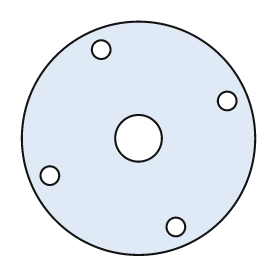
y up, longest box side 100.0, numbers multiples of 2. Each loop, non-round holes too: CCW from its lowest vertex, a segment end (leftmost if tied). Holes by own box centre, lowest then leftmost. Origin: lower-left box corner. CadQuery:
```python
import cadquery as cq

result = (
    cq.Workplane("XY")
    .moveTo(50.0, 50.0)
    .circle(50.0)
    .moveTo(66.0, 12.0)
    .circle(4.0)
    .moveTo(12.0, 34.0)
    .circle(4.0)
    .moveTo(50.0, 50.0)
    .circle(10.0)
    .moveTo(88.0, 66.0)
    .circle(4.0)
    .moveTo(34.0, 88.0)
    .circle(4.0)
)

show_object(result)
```